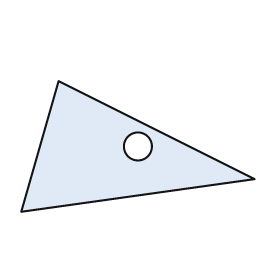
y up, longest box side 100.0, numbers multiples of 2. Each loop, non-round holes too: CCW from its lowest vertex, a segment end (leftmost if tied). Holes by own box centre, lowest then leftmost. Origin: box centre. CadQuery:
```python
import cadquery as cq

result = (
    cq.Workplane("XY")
    .moveTo(-50.0, -28.0)
    .lineTo(50.0, -14.0)
    .lineTo(-34.0, 28.0)
    .close()
    .moveTo(0.0, 0.0)
    .circle(6.0)
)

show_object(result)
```